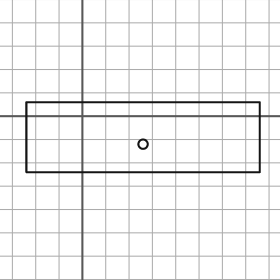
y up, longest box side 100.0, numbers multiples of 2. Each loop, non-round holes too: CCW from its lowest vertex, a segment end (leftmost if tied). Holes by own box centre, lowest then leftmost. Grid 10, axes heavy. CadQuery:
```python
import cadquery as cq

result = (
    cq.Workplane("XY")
    .moveTo(-24.0, -24.0)
    .lineTo(76.0, -24.0)
    .lineTo(76.0, 6.0)
    .lineTo(-24.0, 6.0)
    .close()
    .moveTo(26.0, -12.0)
    .circle(2.0)
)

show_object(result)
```